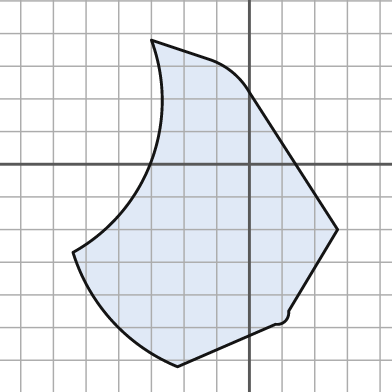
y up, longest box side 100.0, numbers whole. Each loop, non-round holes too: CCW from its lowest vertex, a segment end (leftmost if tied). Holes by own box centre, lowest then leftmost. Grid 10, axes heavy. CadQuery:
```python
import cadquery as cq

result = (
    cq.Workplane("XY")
    .moveTo(-22.0, -62.0)
    .lineTo(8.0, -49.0)
    .threePointArc((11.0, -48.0), (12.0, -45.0))
    .lineTo(27.0, -20.0)
    .lineTo(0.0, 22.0)
    .threePointArc((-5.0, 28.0), (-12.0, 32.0))
    .lineTo(-30.0, 38.0)
    .threePointArc((-30.0, 1.0), (-54.0, -27.0))
    .threePointArc((-42.0, -48.0), (-22.0, -62.0))
    .close()
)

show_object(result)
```